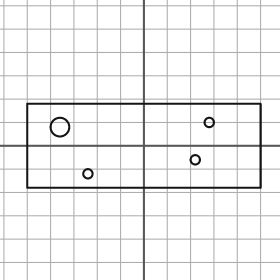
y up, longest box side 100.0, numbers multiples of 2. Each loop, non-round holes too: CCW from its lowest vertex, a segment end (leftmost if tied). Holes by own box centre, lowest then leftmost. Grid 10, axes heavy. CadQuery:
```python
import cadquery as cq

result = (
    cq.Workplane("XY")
    .moveTo(-50.0, -18.0)
    .lineTo(50.0, -18.0)
    .lineTo(50.0, 18.0)
    .lineTo(-50.0, 18.0)
    .close()
    .moveTo(-24.0, -12.0)
    .circle(2.0)
    .moveTo(22.0, -6.0)
    .circle(2.0)
    .moveTo(-36.0, 8.0)
    .circle(4.0)
    .moveTo(28.0, 10.0)
    .circle(2.0)
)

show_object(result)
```